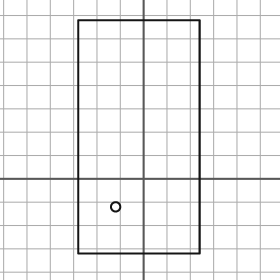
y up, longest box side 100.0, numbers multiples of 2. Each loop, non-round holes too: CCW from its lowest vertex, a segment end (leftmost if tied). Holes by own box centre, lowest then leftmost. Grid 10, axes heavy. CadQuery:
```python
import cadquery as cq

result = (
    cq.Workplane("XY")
    .moveTo(-28.0, -32.0)
    .lineTo(24.0, -32.0)
    .lineTo(24.0, 68.0)
    .lineTo(-28.0, 68.0)
    .close()
    .moveTo(-12.0, -12.0)
    .circle(2.0)
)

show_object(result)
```